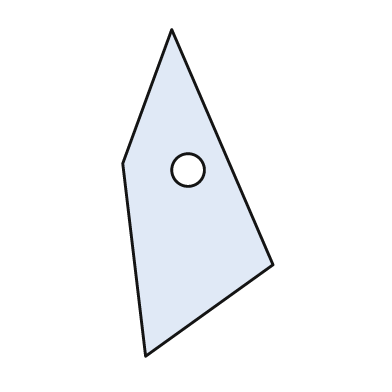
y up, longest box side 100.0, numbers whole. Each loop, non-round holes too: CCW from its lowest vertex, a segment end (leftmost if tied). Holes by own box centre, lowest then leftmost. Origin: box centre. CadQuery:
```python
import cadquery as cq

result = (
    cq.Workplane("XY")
    .moveTo(-16.0, -50.0)
    .lineTo(23.0, -22.0)
    .lineTo(-8.0, 50.0)
    .lineTo(-23.0, 9.0)
    .close()
    .moveTo(-3.0, 7.0)
    .circle(5.0)
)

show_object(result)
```